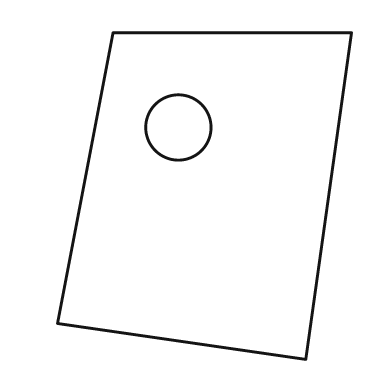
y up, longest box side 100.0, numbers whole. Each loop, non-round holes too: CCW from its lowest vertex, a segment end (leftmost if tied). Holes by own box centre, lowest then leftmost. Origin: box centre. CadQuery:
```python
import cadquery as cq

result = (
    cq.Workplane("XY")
    .moveTo(31.0, -50.0)
    .lineTo(45.0, 50.0)
    .lineTo(-28.0, 50.0)
    .lineTo(-45.0, -39.0)
    .close()
    .moveTo(-8.0, 21.0)
    .circle(10.0)
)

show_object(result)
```